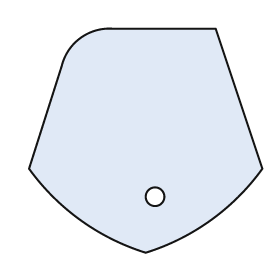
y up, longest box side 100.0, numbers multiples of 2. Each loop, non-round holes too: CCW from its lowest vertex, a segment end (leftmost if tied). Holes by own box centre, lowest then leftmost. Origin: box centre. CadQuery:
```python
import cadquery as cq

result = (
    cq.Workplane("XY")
    .moveTo(0.0, -48.0)
    .threePointArc((28.0, -34.0), (50.0, -12.0))
    .lineTo(30.0, 48.0)
    .lineTo(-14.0, 48.0)
    .threePointArc((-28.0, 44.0), (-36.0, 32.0))
    .lineTo(-50.0, -12.0)
    .threePointArc((-28.0, -34.0), (0.0, -48.0))
    .close()
    .moveTo(4.0, -24.0)
    .circle(4.0)
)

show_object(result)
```